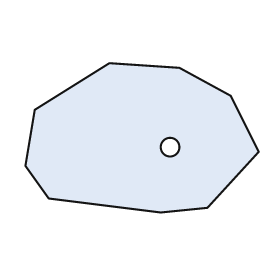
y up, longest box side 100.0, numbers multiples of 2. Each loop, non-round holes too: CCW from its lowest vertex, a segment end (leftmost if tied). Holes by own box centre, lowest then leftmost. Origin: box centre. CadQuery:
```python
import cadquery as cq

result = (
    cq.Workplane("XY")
    .moveTo(8.0, -32.0)
    .lineTo(28.0, -30.0)
    .lineTo(50.0, -6.0)
    .lineTo(38.0, 18.0)
    .lineTo(16.0, 30.0)
    .lineTo(-14.0, 32.0)
    .lineTo(-46.0, 12.0)
    .lineTo(-50.0, -12.0)
    .lineTo(-40.0, -26.0)
    .close()
    .moveTo(12.0, -4.0)
    .circle(4.0)
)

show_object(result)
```